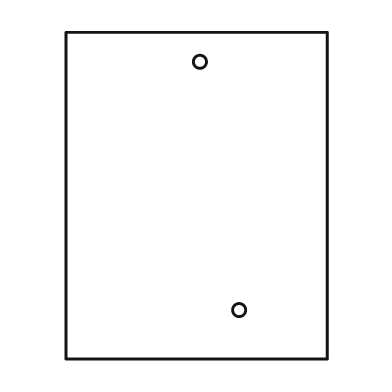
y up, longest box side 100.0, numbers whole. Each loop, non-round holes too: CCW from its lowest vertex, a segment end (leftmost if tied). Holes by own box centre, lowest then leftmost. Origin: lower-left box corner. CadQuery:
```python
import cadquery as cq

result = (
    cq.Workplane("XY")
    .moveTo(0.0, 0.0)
    .lineTo(80.0, 0.0)
    .lineTo(80.0, 100.0)
    .lineTo(0.0, 100.0)
    .close()
    .moveTo(53.0, 15.0)
    .circle(2.0)
    .moveTo(41.0, 91.0)
    .circle(2.0)
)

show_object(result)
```